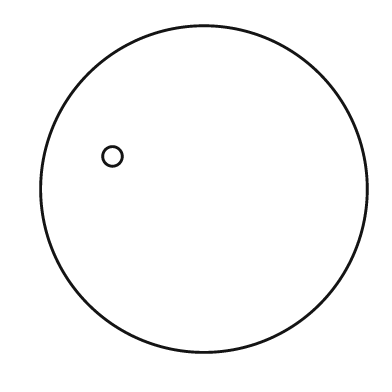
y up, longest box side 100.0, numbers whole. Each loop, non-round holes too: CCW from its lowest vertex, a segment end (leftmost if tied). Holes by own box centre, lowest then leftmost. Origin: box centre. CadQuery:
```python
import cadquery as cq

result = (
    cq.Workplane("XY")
    .moveTo(0.0, 0.0)
    .circle(50.0)
    .moveTo(-28.0, 10.0)
    .circle(3.0)
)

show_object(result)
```